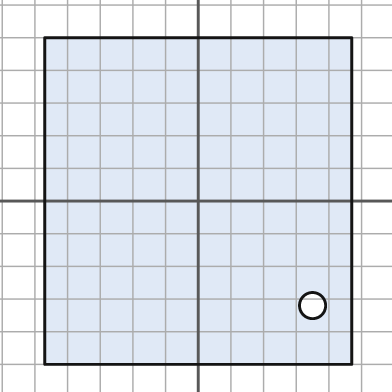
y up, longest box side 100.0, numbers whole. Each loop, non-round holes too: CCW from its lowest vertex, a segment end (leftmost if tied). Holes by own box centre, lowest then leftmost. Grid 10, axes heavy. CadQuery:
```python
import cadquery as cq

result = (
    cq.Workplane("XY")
    .moveTo(-47.0, -50.0)
    .lineTo(47.0, -50.0)
    .lineTo(47.0, 50.0)
    .lineTo(-47.0, 50.0)
    .close()
    .moveTo(35.0, -32.0)
    .circle(4.0)
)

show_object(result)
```